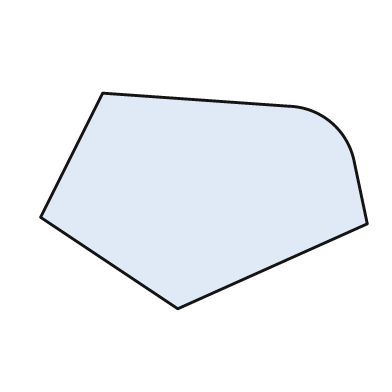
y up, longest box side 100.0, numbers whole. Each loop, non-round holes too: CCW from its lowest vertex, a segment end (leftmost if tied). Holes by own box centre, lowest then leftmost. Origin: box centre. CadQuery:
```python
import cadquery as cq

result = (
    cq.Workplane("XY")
    .moveTo(-8.0, -33.0)
    .lineTo(50.0, -7.0)
    .lineTo(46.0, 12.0)
    .threePointArc((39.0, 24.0), (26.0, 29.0))
    .lineTo(-31.0, 33.0)
    .lineTo(-50.0, -5.0)
    .close()
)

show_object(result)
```